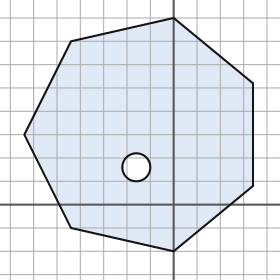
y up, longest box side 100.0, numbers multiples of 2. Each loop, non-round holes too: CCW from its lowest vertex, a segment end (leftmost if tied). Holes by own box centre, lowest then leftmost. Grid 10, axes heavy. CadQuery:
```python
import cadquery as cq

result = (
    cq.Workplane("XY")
    .moveTo(0.0, -20.0)
    .lineTo(34.0, 8.0)
    .lineTo(34.0, 52.0)
    .lineTo(0.0, 80.0)
    .lineTo(-44.0, 70.0)
    .lineTo(-64.0, 30.0)
    .lineTo(-44.0, -10.0)
    .close()
    .moveTo(-16.0, 16.0)
    .circle(6.0)
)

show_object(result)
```